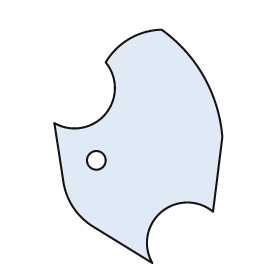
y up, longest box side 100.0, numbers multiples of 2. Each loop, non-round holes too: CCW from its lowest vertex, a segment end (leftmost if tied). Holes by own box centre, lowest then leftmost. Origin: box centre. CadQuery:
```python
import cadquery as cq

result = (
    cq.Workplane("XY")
    .moveTo(6.0, -50.0)
    .threePointArc((10.0, -28.0), (32.0, -28.0))
    .lineTo(36.0, 4.0)
    .threePointArc((28.0, 30.0), (10.0, 50.0))
    .threePointArc((-4.0, 46.0), (-14.0, 36.0))
    .threePointArc((-14.0, 14.0), (-36.0, 10.0))
    .lineTo(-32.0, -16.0)
    .threePointArc((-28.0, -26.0), (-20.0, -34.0))
    .close()
    .moveTo(-18.0, -6.0)
    .circle(4.0)
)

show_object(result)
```